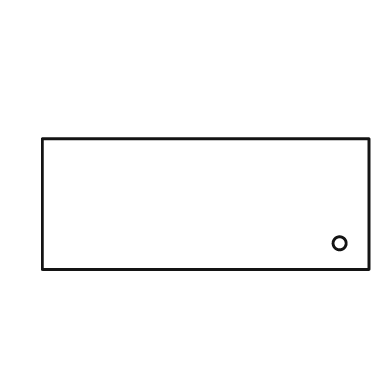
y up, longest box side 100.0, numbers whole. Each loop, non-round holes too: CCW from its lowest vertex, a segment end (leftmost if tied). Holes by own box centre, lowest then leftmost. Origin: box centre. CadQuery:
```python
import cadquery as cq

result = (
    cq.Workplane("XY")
    .moveTo(-50.0, -20.0)
    .lineTo(50.0, -20.0)
    .lineTo(50.0, 20.0)
    .lineTo(-50.0, 20.0)
    .close()
    .moveTo(41.0, -12.0)
    .circle(2.0)
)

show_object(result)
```